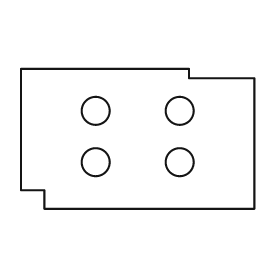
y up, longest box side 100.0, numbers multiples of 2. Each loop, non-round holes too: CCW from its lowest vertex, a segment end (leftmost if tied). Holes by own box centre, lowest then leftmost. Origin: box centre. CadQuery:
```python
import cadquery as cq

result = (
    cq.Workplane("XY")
    .moveTo(-40.0, -30.0)
    .lineTo(50.0, -30.0)
    .lineTo(50.0, 26.0)
    .lineTo(22.0, 26.0)
    .lineTo(22.0, 30.0)
    .lineTo(-50.0, 30.0)
    .lineTo(-50.0, -22.0)
    .lineTo(-40.0, -22.0)
    .close()
    .moveTo(-18.0, -10.0)
    .circle(6.0)
    .moveTo(18.0, -10.0)
    .circle(6.0)
    .moveTo(-18.0, 12.0)
    .circle(6.0)
    .moveTo(18.0, 12.0)
    .circle(6.0)
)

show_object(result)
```